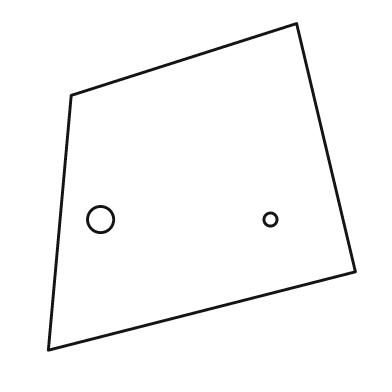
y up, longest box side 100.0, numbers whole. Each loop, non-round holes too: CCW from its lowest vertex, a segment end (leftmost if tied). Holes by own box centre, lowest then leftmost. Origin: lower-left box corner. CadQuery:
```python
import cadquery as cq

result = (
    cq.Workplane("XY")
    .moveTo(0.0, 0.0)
    .lineTo(94.0, 24.0)
    .lineTo(76.0, 100.0)
    .lineTo(7.0, 78.0)
    .close()
    .moveTo(16.0, 40.0)
    .circle(4.0)
    .moveTo(68.0, 40.0)
    .circle(2.0)
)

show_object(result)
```